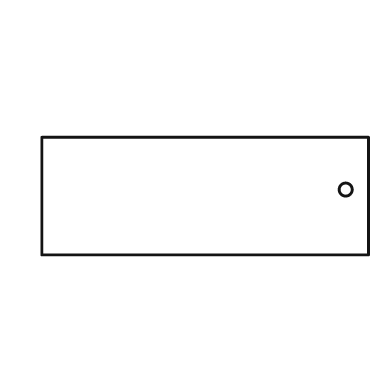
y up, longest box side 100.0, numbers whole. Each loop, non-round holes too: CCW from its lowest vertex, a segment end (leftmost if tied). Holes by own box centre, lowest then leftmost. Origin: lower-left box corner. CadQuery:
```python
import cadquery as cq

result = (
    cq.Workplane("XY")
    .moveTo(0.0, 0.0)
    .lineTo(100.0, 0.0)
    .lineTo(100.0, 36.0)
    .lineTo(0.0, 36.0)
    .close()
    .moveTo(93.0, 20.0)
    .circle(2.0)
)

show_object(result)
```